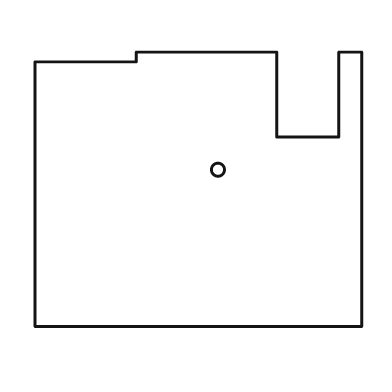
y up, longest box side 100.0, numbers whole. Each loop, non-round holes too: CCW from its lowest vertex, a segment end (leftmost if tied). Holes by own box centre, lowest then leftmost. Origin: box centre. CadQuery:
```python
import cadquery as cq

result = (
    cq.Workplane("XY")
    .moveTo(-50.0, -42.0)
    .lineTo(50.0, -42.0)
    .lineTo(50.0, 42.0)
    .lineTo(43.0, 42.0)
    .lineTo(43.0, 16.0)
    .lineTo(24.0, 16.0)
    .lineTo(24.0, 42.0)
    .lineTo(-19.0, 42.0)
    .lineTo(-19.0, 39.0)
    .lineTo(-50.0, 39.0)
    .close()
    .moveTo(6.0, 6.0)
    .circle(2.0)
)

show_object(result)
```